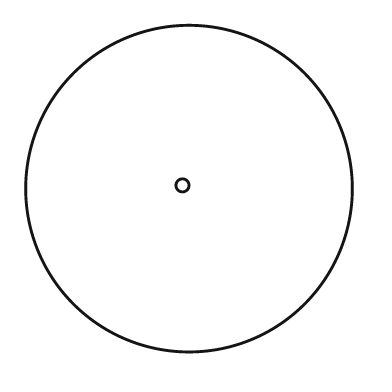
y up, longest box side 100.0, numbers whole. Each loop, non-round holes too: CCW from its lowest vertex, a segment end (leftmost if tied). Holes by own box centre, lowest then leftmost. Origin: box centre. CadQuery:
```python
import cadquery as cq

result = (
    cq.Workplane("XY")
    .moveTo(0.0, 0.0)
    .circle(50.0)
    .moveTo(-2.0, 1.0)
    .circle(2.0)
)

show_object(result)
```